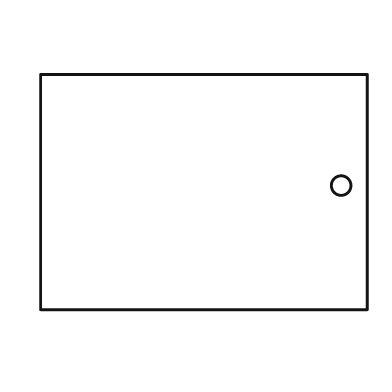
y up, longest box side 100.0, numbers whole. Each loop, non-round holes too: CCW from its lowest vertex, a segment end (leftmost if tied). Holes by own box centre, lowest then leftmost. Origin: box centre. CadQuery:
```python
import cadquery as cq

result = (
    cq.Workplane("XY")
    .moveTo(-50.0, -36.0)
    .lineTo(50.0, -36.0)
    .lineTo(50.0, 36.0)
    .lineTo(-50.0, 36.0)
    .close()
    .moveTo(42.0, 2.0)
    .circle(3.0)
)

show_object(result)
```